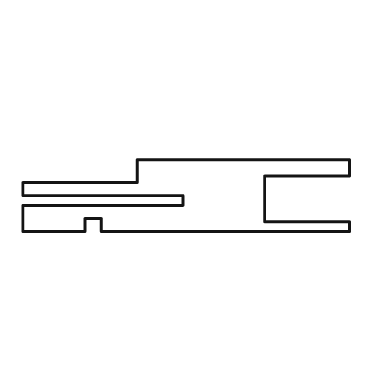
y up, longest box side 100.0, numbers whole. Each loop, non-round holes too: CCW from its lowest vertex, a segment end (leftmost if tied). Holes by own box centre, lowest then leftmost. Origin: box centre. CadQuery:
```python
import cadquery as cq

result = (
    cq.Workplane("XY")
    .moveTo(-50.0, -11.0)
    .lineTo(-31.0, -11.0)
    .lineTo(-31.0, -7.0)
    .lineTo(-26.0, -7.0)
    .lineTo(-26.0, -11.0)
    .lineTo(50.0, -11.0)
    .lineTo(50.0, -8.0)
    .lineTo(24.0, -8.0)
    .lineTo(24.0, 6.0)
    .lineTo(50.0, 6.0)
    .lineTo(50.0, 11.0)
    .lineTo(-15.0, 11.0)
    .lineTo(-15.0, 4.0)
    .lineTo(-50.0, 4.0)
    .lineTo(-50.0, 0.0)
    .lineTo(-1.0, 0.0)
    .lineTo(-1.0, -3.0)
    .lineTo(-50.0, -3.0)
    .close()
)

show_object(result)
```